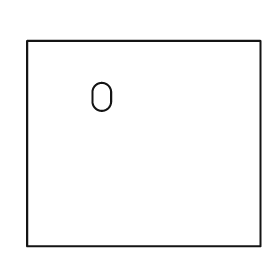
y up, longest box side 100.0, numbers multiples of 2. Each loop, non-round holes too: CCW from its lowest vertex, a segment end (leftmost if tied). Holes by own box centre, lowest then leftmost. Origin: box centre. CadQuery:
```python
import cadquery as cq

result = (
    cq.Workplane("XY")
    .moveTo(-50.0, -44.0)
    .lineTo(50.0, -44.0)
    .lineTo(50.0, 44.0)
    .lineTo(-50.0, 44.0)
    .close()
    .moveTo(-22.0, 18.0)
    .threePointArc((-18.0, 14.0), (-14.0, 18.0))
    .lineTo(-14.0, 22.0)
    .threePointArc((-18.0, 26.0), (-22.0, 22.0))
    .close()
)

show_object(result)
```